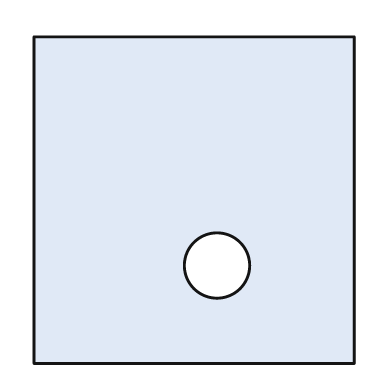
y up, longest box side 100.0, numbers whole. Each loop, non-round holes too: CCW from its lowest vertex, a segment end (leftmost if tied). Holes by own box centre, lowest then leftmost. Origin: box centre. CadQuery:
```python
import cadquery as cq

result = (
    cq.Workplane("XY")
    .moveTo(-49.0, -50.0)
    .lineTo(49.0, -50.0)
    .lineTo(49.0, 50.0)
    .lineTo(-49.0, 50.0)
    .close()
    .moveTo(7.0, -20.0)
    .circle(10.0)
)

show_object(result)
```